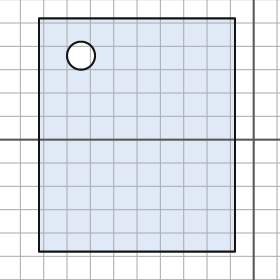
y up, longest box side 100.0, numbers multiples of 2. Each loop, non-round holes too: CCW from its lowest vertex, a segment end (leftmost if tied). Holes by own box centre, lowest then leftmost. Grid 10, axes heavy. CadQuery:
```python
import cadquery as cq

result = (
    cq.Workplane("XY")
    .moveTo(-92.0, -48.0)
    .lineTo(-8.0, -48.0)
    .lineTo(-8.0, 52.0)
    .lineTo(-92.0, 52.0)
    .close()
    .moveTo(-74.0, 36.0)
    .circle(6.0)
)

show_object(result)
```